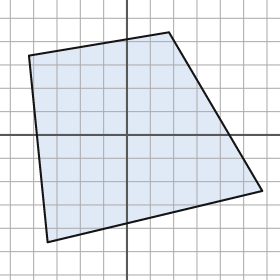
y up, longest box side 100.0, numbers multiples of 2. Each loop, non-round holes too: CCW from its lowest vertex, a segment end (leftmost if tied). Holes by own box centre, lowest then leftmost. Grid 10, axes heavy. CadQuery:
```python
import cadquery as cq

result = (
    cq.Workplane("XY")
    .moveTo(-34.0, -46.0)
    .lineTo(58.0, -24.0)
    .lineTo(18.0, 44.0)
    .lineTo(-42.0, 34.0)
    .close()
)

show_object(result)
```